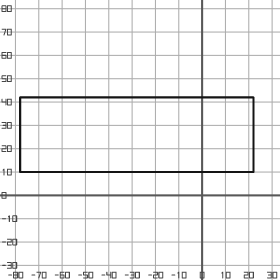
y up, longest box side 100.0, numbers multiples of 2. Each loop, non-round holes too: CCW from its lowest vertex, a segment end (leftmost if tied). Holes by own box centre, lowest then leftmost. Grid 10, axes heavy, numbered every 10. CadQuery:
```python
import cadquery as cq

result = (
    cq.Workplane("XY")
    .moveTo(-78.0, 10.0)
    .lineTo(22.0, 10.0)
    .lineTo(22.0, 42.0)
    .lineTo(-78.0, 42.0)
    .close()
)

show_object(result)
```